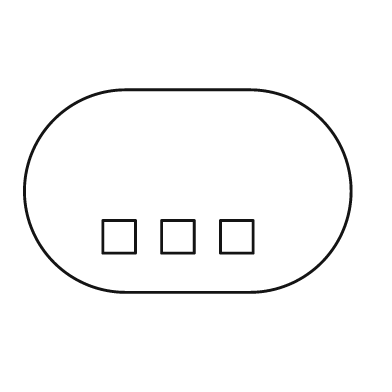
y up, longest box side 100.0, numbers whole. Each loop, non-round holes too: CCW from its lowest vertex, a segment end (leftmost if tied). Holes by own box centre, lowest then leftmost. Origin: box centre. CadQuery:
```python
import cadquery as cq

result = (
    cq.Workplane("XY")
    .moveTo(-19.0, -31.0)
    .lineTo(19.0, -31.0)
    .threePointArc((50.0, 0.0), (19.0, 31.0))
    .lineTo(-19.0, 31.0)
    .threePointArc((-50.0, 0.0), (-19.0, -31.0))
    .close()
    .moveTo(-26.0, -19.0)
    .lineTo(-16.0, -19.0)
    .lineTo(-16.0, -9.0)
    .lineTo(-26.0, -9.0)
    .close()
    .moveTo(-8.0, -19.0)
    .lineTo(2.0, -19.0)
    .lineTo(2.0, -9.0)
    .lineTo(-8.0, -9.0)
    .close()
    .moveTo(10.0, -19.0)
    .lineTo(20.0, -19.0)
    .lineTo(20.0, -9.0)
    .lineTo(10.0, -9.0)
    .close()
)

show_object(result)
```